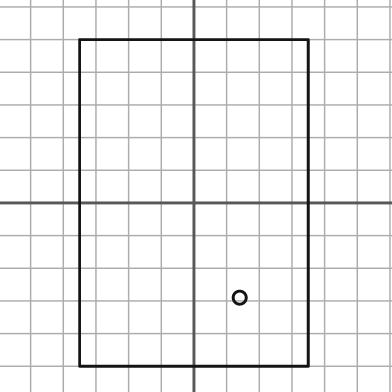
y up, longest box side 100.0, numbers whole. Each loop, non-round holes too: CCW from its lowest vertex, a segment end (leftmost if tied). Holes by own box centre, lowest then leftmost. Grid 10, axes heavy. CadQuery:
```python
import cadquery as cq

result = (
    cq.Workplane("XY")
    .moveTo(-35.0, -50.0)
    .lineTo(35.0, -50.0)
    .lineTo(35.0, 50.0)
    .lineTo(-35.0, 50.0)
    .close()
    .moveTo(14.0, -29.0)
    .circle(2.0)
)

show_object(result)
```